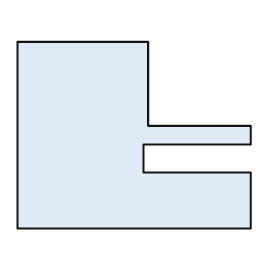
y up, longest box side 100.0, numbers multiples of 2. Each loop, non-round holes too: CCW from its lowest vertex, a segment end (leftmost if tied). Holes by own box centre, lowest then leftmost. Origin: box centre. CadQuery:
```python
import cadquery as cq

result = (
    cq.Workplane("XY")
    .moveTo(-50.0, -40.0)
    .lineTo(50.0, -40.0)
    .lineTo(50.0, -16.0)
    .lineTo(4.0, -16.0)
    .lineTo(4.0, -4.0)
    .lineTo(50.0, -4.0)
    .lineTo(50.0, 4.0)
    .lineTo(6.0, 4.0)
    .lineTo(6.0, 40.0)
    .lineTo(-50.0, 40.0)
    .close()
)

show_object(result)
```